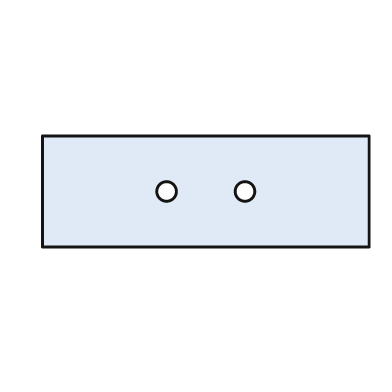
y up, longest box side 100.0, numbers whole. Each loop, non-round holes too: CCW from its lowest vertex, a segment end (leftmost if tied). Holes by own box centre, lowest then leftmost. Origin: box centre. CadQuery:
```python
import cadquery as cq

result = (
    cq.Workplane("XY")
    .moveTo(-50.0, -17.0)
    .lineTo(50.0, -17.0)
    .lineTo(50.0, 17.0)
    .lineTo(-50.0, 17.0)
    .close()
    .moveTo(-12.0, 0.0)
    .circle(3.0)
    .moveTo(12.0, 0.0)
    .circle(3.0)
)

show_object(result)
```